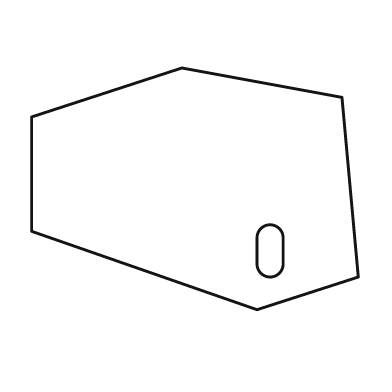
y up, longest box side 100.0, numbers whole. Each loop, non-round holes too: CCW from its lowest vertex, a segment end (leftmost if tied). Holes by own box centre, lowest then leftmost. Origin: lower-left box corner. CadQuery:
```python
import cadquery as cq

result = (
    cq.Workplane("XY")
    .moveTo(69.0, 0.0)
    .lineTo(100.0, 10.0)
    .lineTo(95.0, 65.0)
    .lineTo(46.0, 74.0)
    .lineTo(0.0, 59.0)
    .lineTo(0.0, 24.0)
    .close()
    .moveTo(69.0, 14.0)
    .threePointArc((73.0, 10.0), (77.0, 14.0))
    .lineTo(77.0, 22.0)
    .threePointArc((73.0, 26.0), (69.0, 22.0))
    .close()
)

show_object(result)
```